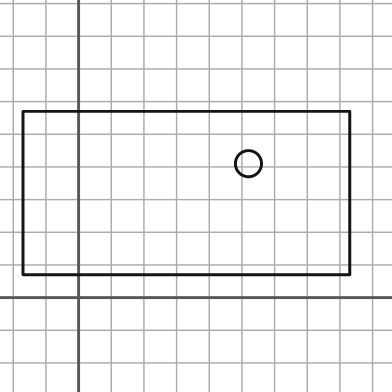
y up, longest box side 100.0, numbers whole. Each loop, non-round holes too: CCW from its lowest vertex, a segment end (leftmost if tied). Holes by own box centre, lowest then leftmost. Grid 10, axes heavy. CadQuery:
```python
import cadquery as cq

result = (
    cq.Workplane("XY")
    .moveTo(-17.0, 7.0)
    .lineTo(83.0, 7.0)
    .lineTo(83.0, 57.0)
    .lineTo(-17.0, 57.0)
    .close()
    .moveTo(52.0, 41.0)
    .circle(4.0)
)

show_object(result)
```